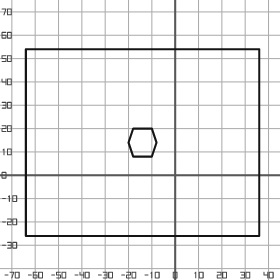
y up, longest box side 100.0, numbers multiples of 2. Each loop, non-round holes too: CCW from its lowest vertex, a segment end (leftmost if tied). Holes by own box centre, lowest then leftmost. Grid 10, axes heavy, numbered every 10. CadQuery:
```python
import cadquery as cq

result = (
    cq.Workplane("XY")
    .moveTo(-64.0, -26.0)
    .lineTo(36.0, -26.0)
    .lineTo(36.0, 54.0)
    .lineTo(-64.0, 54.0)
    .close()
    .moveTo(-18.0, 8.0)
    .lineTo(-10.0, 8.0)
    .lineTo(-8.0, 14.0)
    .lineTo(-10.0, 20.0)
    .lineTo(-18.0, 20.0)
    .lineTo(-20.0, 14.0)
    .close()
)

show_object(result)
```